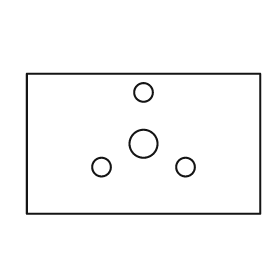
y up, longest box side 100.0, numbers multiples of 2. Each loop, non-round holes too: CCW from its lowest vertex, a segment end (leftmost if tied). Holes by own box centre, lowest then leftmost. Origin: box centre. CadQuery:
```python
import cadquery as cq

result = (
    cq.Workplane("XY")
    .moveTo(-50.0, -30.0)
    .lineTo(50.0, -30.0)
    .lineTo(50.0, 30.0)
    .lineTo(-50.0, 30.0)
    .close()
    .moveTo(-18.0, -10.0)
    .circle(4.0)
    .moveTo(18.0, -10.0)
    .circle(4.0)
    .moveTo(0.0, 0.0)
    .circle(6.0)
    .moveTo(0.0, 22.0)
    .circle(4.0)
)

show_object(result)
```